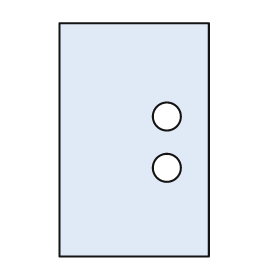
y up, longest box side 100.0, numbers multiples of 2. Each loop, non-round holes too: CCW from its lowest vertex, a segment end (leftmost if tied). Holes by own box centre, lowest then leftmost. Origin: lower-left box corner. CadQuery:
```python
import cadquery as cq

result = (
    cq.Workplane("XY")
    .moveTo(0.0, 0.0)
    .lineTo(64.0, 0.0)
    .lineTo(64.0, 100.0)
    .lineTo(0.0, 100.0)
    .close()
    .moveTo(46.0, 38.0)
    .circle(6.0)
    .moveTo(46.0, 60.0)
    .circle(6.0)
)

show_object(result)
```